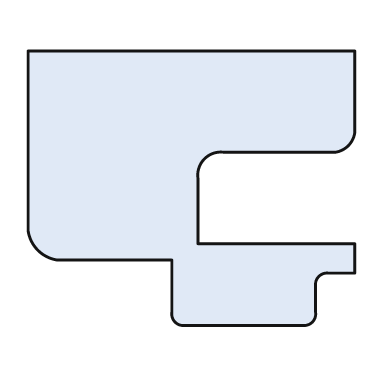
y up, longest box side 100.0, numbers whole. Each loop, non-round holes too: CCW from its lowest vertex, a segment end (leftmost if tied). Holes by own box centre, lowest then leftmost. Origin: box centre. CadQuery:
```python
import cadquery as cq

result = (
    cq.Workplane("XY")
    .moveTo(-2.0, -42.0)
    .lineTo(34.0, -42.0)
    .threePointArc((37.0, -41.0), (38.0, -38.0))
    .lineTo(38.0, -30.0)
    .threePointArc((39.0, -27.0), (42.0, -26.0))
    .lineTo(50.0, -26.0)
    .lineTo(50.0, -17.0)
    .lineTo(2.0, -17.0)
    .lineTo(2.0, 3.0)
    .threePointArc((4.0, 9.0), (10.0, 11.0))
    .lineTo(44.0, 11.0)
    .threePointArc((48.0, 13.0), (50.0, 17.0))
    .lineTo(50.0, 42.0)
    .lineTo(-50.0, 42.0)
    .lineTo(-50.0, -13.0)
    .threePointArc((-47.0, -19.0), (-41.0, -22.0))
    .lineTo(-6.0, -22.0)
    .lineTo(-6.0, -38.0)
    .threePointArc((-5.0, -41.0), (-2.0, -42.0))
    .close()
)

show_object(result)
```